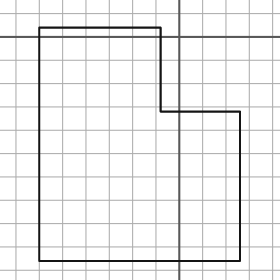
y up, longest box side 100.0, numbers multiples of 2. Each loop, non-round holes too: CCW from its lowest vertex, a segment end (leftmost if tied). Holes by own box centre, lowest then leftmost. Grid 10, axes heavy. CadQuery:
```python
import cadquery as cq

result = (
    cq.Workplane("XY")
    .moveTo(-60.0, -96.0)
    .lineTo(26.0, -96.0)
    .lineTo(26.0, -32.0)
    .lineTo(-8.0, -32.0)
    .lineTo(-8.0, 4.0)
    .lineTo(-60.0, 4.0)
    .close()
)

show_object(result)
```